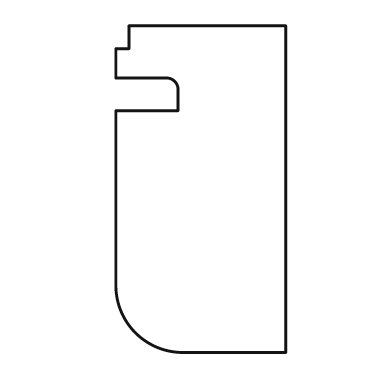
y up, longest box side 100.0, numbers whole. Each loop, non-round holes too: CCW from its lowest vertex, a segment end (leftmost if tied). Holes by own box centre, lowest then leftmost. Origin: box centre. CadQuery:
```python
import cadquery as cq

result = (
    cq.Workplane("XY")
    .moveTo(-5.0, -50.0)
    .lineTo(26.0, -50.0)
    .lineTo(26.0, 50.0)
    .lineTo(-22.0, 50.0)
    .lineTo(-22.0, 43.0)
    .lineTo(-26.0, 43.0)
    .lineTo(-26.0, 34.0)
    .lineTo(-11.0, 34.0)
    .threePointArc((-8.0, 33.0), (-7.0, 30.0))
    .lineTo(-7.0, 24.0)
    .lineTo(-26.0, 24.0)
    .lineTo(-26.0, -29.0)
    .threePointArc((-20.0, -44.0), (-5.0, -50.0))
    .close()
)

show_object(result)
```